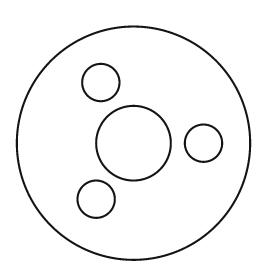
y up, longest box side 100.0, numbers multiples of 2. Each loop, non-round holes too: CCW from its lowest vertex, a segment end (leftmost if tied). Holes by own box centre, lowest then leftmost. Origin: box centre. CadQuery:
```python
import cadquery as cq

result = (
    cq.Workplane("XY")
    .moveTo(0.0, 0.0)
    .circle(50.0)
    .moveTo(-16.0, -24.0)
    .circle(8.0)
    .moveTo(0.0, 0.0)
    .circle(16.0)
    .moveTo(30.0, 0.0)
    .circle(8.0)
    .moveTo(-14.0, 26.0)
    .circle(8.0)
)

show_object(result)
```